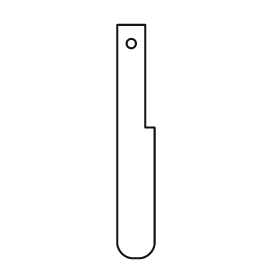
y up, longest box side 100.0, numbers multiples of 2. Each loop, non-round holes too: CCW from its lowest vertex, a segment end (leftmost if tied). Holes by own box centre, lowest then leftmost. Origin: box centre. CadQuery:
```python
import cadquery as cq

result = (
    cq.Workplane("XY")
    .moveTo(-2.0, -50.0)
    .lineTo(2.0, -50.0)
    .threePointArc((6.0, -48.0), (8.0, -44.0))
    .lineTo(8.0, 6.0)
    .lineTo(4.0, 6.0)
    .lineTo(4.0, 50.0)
    .lineTo(-8.0, 50.0)
    .lineTo(-8.0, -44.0)
    .threePointArc((-6.0, -48.0), (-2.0, -50.0))
    .close()
    .moveTo(-2.0, 42.0)
    .circle(2.0)
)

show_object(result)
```